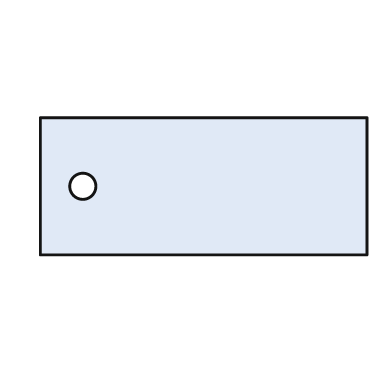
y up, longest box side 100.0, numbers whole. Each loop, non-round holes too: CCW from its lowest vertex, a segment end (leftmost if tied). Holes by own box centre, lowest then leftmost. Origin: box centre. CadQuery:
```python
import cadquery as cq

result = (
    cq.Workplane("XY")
    .moveTo(-50.0, -21.0)
    .lineTo(50.0, -21.0)
    .lineTo(50.0, 21.0)
    .lineTo(-50.0, 21.0)
    .close()
    .moveTo(-37.0, 0.0)
    .circle(4.0)
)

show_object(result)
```